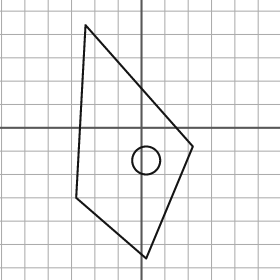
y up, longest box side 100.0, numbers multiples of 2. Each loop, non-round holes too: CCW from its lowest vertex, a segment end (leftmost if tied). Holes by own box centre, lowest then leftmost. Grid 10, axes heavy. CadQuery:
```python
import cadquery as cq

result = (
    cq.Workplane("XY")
    .moveTo(2.0, -56.0)
    .lineTo(22.0, -8.0)
    .lineTo(-24.0, 44.0)
    .lineTo(-28.0, -30.0)
    .close()
    .moveTo(2.0, -14.0)
    .circle(6.0)
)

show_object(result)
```